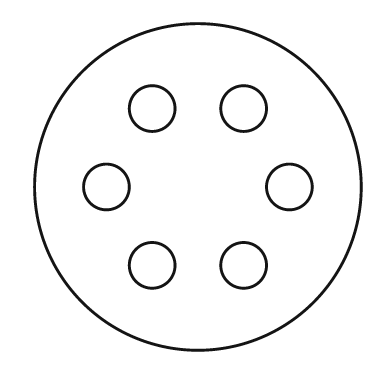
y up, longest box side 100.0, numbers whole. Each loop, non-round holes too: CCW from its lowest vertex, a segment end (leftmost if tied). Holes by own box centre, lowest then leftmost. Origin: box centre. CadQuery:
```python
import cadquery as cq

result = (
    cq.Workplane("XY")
    .moveTo(0.0, 0.0)
    .circle(50.0)
    .moveTo(-14.0, -24.0)
    .circle(7.0)
    .moveTo(14.0, -24.0)
    .circle(7.0)
    .moveTo(-28.0, 0.0)
    .circle(7.0)
    .moveTo(28.0, 0.0)
    .circle(7.0)
    .moveTo(-14.0, 24.0)
    .circle(7.0)
    .moveTo(14.0, 24.0)
    .circle(7.0)
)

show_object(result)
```